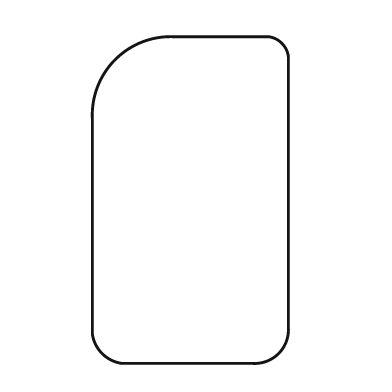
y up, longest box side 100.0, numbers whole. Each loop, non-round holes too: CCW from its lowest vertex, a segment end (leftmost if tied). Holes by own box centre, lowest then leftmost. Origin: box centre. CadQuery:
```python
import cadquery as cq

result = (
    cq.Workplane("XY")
    .moveTo(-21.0, -50.0)
    .lineTo(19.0, -50.0)
    .threePointArc((27.0, -47.0), (30.0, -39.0))
    .lineTo(30.0, 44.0)
    .threePointArc((28.0, 48.0), (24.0, 50.0))
    .lineTo(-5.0, 50.0)
    .threePointArc((-23.0, 43.0), (-30.0, 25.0))
    .lineTo(-30.0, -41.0)
    .threePointArc((-27.0, -47.0), (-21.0, -50.0))
    .close()
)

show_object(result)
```